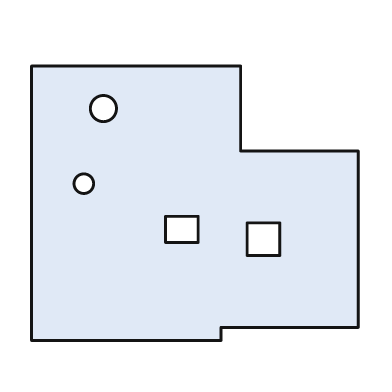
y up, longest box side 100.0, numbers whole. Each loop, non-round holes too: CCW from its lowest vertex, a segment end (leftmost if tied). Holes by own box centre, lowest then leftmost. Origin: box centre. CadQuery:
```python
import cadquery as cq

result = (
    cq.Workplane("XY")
    .moveTo(-50.0, -42.0)
    .lineTo(8.0, -42.0)
    .lineTo(8.0, -38.0)
    .lineTo(50.0, -38.0)
    .lineTo(50.0, 16.0)
    .lineTo(14.0, 16.0)
    .lineTo(14.0, 42.0)
    .lineTo(-50.0, 42.0)
    .close()
    .moveTo(16.0, -16.0)
    .lineTo(26.0, -16.0)
    .lineTo(26.0, -6.0)
    .lineTo(16.0, -6.0)
    .close()
    .moveTo(-9.0, -12.0)
    .lineTo(1.0, -12.0)
    .lineTo(1.0, -4.0)
    .lineTo(-9.0, -4.0)
    .close()
    .moveTo(-34.0, 6.0)
    .circle(3.0)
    .moveTo(-28.0, 29.0)
    .circle(4.0)
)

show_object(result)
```